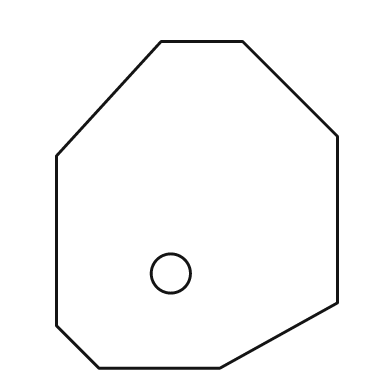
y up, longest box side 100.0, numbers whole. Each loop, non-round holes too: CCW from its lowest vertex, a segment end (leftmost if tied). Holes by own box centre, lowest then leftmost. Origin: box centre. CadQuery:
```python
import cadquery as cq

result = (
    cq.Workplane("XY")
    .moveTo(-30.0, -50.0)
    .lineTo(7.0, -50.0)
    .lineTo(43.0, -30.0)
    .lineTo(43.0, 21.0)
    .lineTo(14.0, 50.0)
    .lineTo(-11.0, 50.0)
    .lineTo(-43.0, 15.0)
    .lineTo(-43.0, -37.0)
    .close()
    .moveTo(-8.0, -21.0)
    .circle(6.0)
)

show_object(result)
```